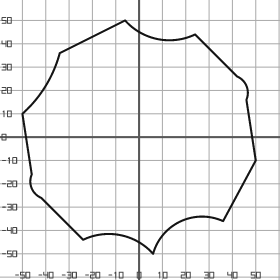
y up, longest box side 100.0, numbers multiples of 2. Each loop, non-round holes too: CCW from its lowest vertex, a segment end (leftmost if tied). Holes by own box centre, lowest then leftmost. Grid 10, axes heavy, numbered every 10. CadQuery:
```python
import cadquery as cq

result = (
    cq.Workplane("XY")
    .moveTo(6.0, -50.0)
    .threePointArc((18.0, -36.0), (36.0, -36.0))
    .lineTo(50.0, -10.0)
    .lineTo(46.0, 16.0)
    .threePointArc((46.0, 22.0), (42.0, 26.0))
    .lineTo(24.0, 44.0)
    .threePointArc((8.0, 42.0), (-6.0, 50.0))
    .lineTo(-34.0, 36.0)
    .threePointArc((-40.0, 22.0), (-50.0, 10.0))
    .lineTo(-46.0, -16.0)
    .threePointArc((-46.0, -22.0), (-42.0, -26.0))
    .lineTo(-24.0, -44.0)
    .threePointArc((-8.0, -42.0), (6.0, -50.0))
    .close()
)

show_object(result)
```